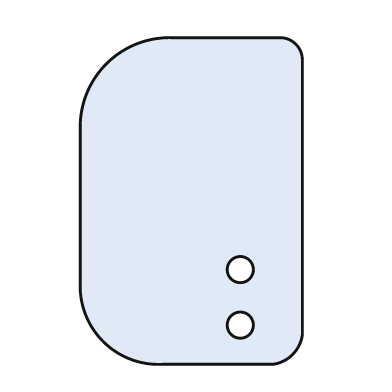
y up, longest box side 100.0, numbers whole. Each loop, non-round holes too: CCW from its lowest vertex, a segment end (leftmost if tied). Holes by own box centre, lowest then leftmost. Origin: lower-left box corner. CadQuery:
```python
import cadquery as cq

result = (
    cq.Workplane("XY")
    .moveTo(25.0, 0.0)
    .lineTo(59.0, 0.0)
    .threePointArc((65.0, 3.0), (68.0, 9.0))
    .lineTo(68.0, 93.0)
    .threePointArc((66.0, 98.0), (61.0, 100.0))
    .lineTo(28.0, 100.0)
    .threePointArc((8.0, 92.0), (0.0, 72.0))
    .lineTo(0.0, 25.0)
    .threePointArc((7.0, 7.0), (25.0, 0.0))
    .close()
    .moveTo(49.0, 12.0)
    .circle(4.0)
    .moveTo(49.0, 29.0)
    .circle(4.0)
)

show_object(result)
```